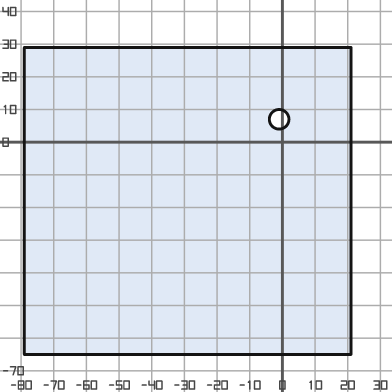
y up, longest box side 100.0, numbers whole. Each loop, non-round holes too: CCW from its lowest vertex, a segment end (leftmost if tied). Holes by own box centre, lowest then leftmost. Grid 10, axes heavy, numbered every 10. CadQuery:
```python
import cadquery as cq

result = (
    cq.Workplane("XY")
    .moveTo(-79.0, -65.0)
    .lineTo(21.0, -65.0)
    .lineTo(21.0, 29.0)
    .lineTo(-79.0, 29.0)
    .close()
    .moveTo(-1.0, 7.0)
    .circle(3.0)
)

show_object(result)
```